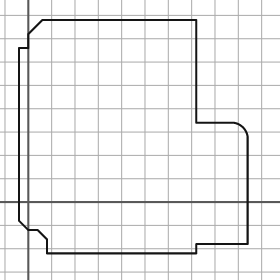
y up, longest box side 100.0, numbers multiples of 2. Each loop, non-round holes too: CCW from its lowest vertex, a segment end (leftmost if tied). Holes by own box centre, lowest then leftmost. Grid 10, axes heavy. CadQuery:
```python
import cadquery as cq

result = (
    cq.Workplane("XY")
    .moveTo(8.0, -22.0)
    .lineTo(72.0, -22.0)
    .lineTo(72.0, -18.0)
    .lineTo(94.0, -18.0)
    .lineTo(94.0, 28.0)
    .threePointArc((92.0, 32.0), (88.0, 34.0))
    .lineTo(72.0, 34.0)
    .lineTo(72.0, 78.0)
    .lineTo(6.0, 78.0)
    .lineTo(0.0, 72.0)
    .lineTo(0.0, 66.0)
    .lineTo(-4.0, 66.0)
    .lineTo(-4.0, -8.0)
    .lineTo(0.0, -12.0)
    .lineTo(4.0, -12.0)
    .lineTo(8.0, -16.0)
    .close()
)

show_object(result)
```